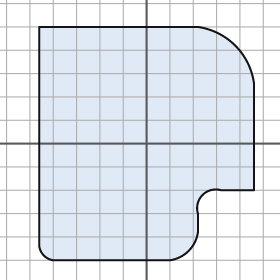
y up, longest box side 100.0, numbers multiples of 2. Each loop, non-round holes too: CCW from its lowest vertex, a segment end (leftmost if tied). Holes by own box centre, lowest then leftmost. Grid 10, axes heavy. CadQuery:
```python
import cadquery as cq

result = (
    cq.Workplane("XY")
    .moveTo(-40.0, -50.0)
    .lineTo(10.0, -50.0)
    .threePointArc((18.0, -46.0), (22.0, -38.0))
    .lineTo(22.0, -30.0)
    .threePointArc((24.0, -22.0), (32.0, -20.0))
    .lineTo(46.0, -20.0)
    .lineTo(46.0, 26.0)
    .threePointArc((38.0, 42.0), (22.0, 50.0))
    .lineTo(-46.0, 50.0)
    .lineTo(-46.0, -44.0)
    .threePointArc((-44.0, -48.0), (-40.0, -50.0))
    .close()
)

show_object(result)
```